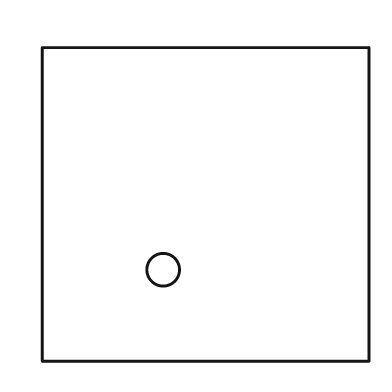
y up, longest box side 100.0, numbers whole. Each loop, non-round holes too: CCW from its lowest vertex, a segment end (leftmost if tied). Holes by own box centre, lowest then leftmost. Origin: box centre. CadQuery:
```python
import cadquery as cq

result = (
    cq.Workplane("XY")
    .moveTo(-50.0, -48.0)
    .lineTo(50.0, -48.0)
    .lineTo(50.0, 48.0)
    .lineTo(-50.0, 48.0)
    .close()
    .moveTo(-13.0, -20.0)
    .circle(5.0)
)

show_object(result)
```